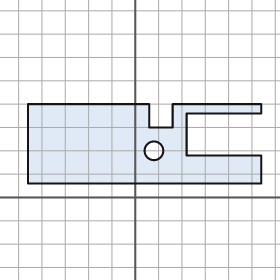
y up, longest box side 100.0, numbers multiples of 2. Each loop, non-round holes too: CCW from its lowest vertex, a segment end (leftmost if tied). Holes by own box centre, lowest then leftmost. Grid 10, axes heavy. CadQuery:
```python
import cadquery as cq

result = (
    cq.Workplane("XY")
    .moveTo(-46.0, 6.0)
    .lineTo(54.0, 6.0)
    .lineTo(54.0, 18.0)
    .lineTo(22.0, 18.0)
    .lineTo(22.0, 36.0)
    .lineTo(54.0, 36.0)
    .lineTo(54.0, 40.0)
    .lineTo(16.0, 40.0)
    .lineTo(16.0, 30.0)
    .lineTo(6.0, 30.0)
    .lineTo(6.0, 40.0)
    .lineTo(-46.0, 40.0)
    .close()
    .moveTo(8.0, 20.0)
    .circle(4.0)
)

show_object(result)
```